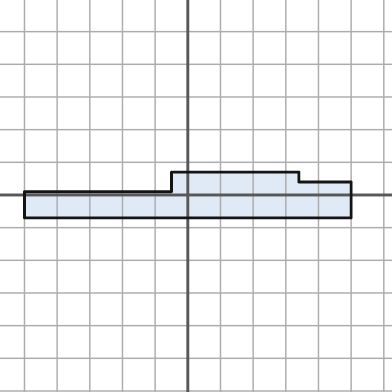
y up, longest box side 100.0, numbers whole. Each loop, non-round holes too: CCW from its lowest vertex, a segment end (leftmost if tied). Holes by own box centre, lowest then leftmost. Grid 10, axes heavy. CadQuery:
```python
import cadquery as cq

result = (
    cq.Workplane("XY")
    .moveTo(-50.0, -7.0)
    .lineTo(50.0, -7.0)
    .lineTo(50.0, 4.0)
    .lineTo(34.0, 4.0)
    .lineTo(34.0, 7.0)
    .lineTo(-5.0, 7.0)
    .lineTo(-5.0, 1.0)
    .lineTo(-50.0, 1.0)
    .close()
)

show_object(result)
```